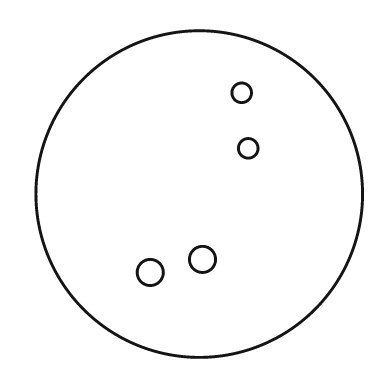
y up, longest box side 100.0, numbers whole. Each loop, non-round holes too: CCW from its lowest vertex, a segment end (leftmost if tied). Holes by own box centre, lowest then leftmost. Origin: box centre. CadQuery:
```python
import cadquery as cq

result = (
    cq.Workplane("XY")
    .moveTo(0.0, 0.0)
    .circle(50.0)
    .moveTo(-15.0, -24.0)
    .circle(4.0)
    .moveTo(1.0, -20.0)
    .circle(4.0)
    .moveTo(15.0, 14.0)
    .circle(3.0)
    .moveTo(13.0, 31.0)
    .circle(3.0)
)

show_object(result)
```